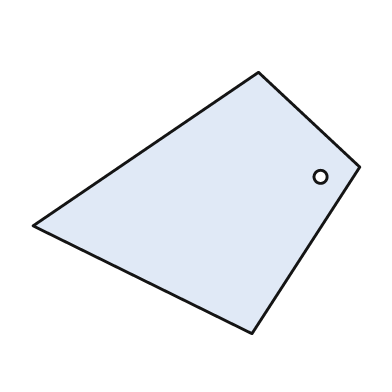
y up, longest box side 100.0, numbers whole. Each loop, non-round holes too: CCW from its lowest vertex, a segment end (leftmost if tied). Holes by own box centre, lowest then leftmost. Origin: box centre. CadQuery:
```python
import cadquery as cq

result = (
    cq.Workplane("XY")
    .moveTo(17.0, -40.0)
    .lineTo(50.0, 11.0)
    .lineTo(19.0, 40.0)
    .lineTo(-50.0, -7.0)
    .close()
    .moveTo(38.0, 8.0)
    .circle(2.0)
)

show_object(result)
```